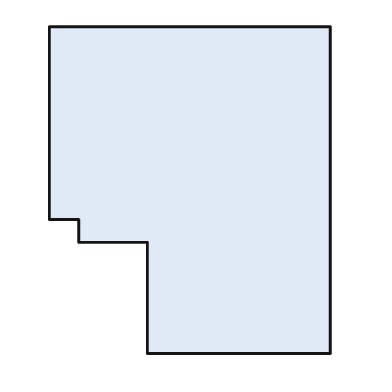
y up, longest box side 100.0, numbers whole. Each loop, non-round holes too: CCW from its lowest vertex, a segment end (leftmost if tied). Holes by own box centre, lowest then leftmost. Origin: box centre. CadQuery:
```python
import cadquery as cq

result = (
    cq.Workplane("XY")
    .moveTo(-13.0, -50.0)
    .lineTo(43.0, -50.0)
    .lineTo(43.0, 50.0)
    .lineTo(-43.0, 50.0)
    .lineTo(-43.0, -9.0)
    .lineTo(-34.0, -9.0)
    .lineTo(-34.0, -16.0)
    .lineTo(-13.0, -16.0)
    .close()
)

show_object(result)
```